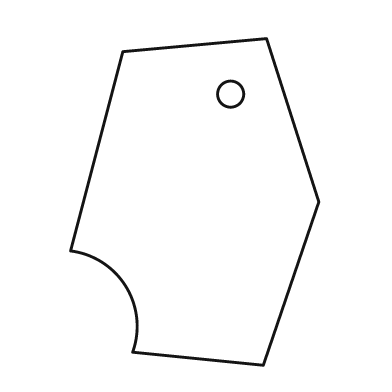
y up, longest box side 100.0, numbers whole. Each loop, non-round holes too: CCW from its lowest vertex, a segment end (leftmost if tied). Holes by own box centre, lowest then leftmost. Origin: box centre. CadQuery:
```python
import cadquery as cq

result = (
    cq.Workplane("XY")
    .moveTo(21.0, -50.0)
    .lineTo(38.0, 0.0)
    .lineTo(22.0, 50.0)
    .lineTo(-22.0, 46.0)
    .lineTo(-38.0, -15.0)
    .threePointArc((-21.0, -26.0), (-19.0, -46.0))
    .close()
    .moveTo(11.0, 33.0)
    .circle(4.0)
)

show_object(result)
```